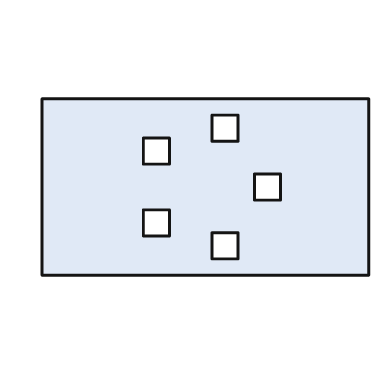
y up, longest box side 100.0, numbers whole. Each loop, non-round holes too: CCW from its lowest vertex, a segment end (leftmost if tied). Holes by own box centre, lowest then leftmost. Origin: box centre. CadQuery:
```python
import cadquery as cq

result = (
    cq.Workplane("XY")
    .moveTo(-50.0, -27.0)
    .lineTo(50.0, -27.0)
    .lineTo(50.0, 27.0)
    .lineTo(-50.0, 27.0)
    .close()
    .moveTo(2.0, -22.0)
    .lineTo(10.0, -22.0)
    .lineTo(10.0, -14.0)
    .lineTo(2.0, -14.0)
    .close()
    .moveTo(-19.0, -15.0)
    .lineTo(-11.0, -15.0)
    .lineTo(-11.0, -7.0)
    .lineTo(-19.0, -7.0)
    .close()
    .moveTo(15.0, -4.0)
    .lineTo(23.0, -4.0)
    .lineTo(23.0, 4.0)
    .lineTo(15.0, 4.0)
    .close()
    .moveTo(-19.0, 7.0)
    .lineTo(-11.0, 7.0)
    .lineTo(-11.0, 15.0)
    .lineTo(-19.0, 15.0)
    .close()
    .moveTo(2.0, 14.0)
    .lineTo(10.0, 14.0)
    .lineTo(10.0, 22.0)
    .lineTo(2.0, 22.0)
    .close()
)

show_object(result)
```